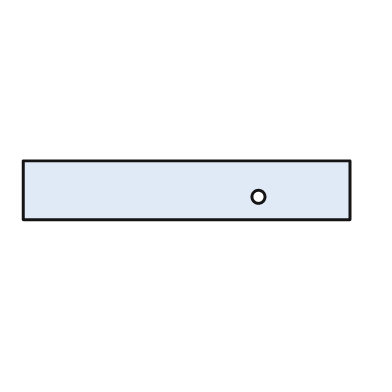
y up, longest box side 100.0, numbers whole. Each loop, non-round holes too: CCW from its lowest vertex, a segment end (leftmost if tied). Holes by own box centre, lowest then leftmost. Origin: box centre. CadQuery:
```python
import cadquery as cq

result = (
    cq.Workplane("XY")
    .moveTo(-50.0, -9.0)
    .lineTo(50.0, -9.0)
    .lineTo(50.0, 9.0)
    .lineTo(-50.0, 9.0)
    .close()
    .moveTo(22.0, -2.0)
    .circle(2.0)
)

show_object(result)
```